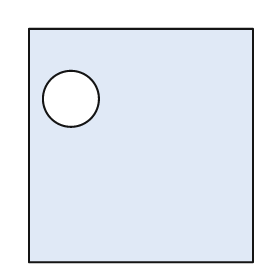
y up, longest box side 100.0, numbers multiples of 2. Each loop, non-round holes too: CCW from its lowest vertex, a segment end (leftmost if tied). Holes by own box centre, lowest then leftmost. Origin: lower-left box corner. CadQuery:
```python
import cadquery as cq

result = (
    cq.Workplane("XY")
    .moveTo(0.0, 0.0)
    .lineTo(96.0, 0.0)
    .lineTo(96.0, 100.0)
    .lineTo(0.0, 100.0)
    .close()
    .moveTo(18.0, 70.0)
    .circle(12.0)
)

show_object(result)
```